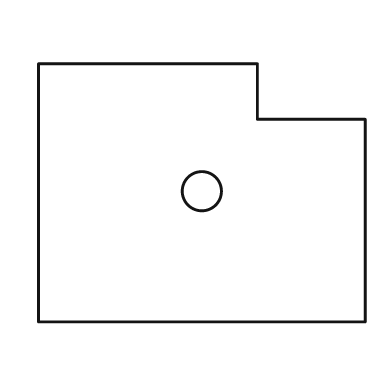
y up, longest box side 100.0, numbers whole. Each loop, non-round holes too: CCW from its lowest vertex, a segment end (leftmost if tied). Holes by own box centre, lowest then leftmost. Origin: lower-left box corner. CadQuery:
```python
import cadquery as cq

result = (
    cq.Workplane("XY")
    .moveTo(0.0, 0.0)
    .lineTo(100.0, 0.0)
    .lineTo(100.0, 62.0)
    .lineTo(67.0, 62.0)
    .lineTo(67.0, 79.0)
    .lineTo(0.0, 79.0)
    .close()
    .moveTo(50.0, 40.0)
    .circle(6.0)
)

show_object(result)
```